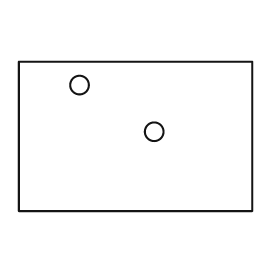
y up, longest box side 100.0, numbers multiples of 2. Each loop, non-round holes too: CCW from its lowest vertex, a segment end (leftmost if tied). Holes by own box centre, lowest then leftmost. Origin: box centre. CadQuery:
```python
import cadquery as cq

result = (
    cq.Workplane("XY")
    .moveTo(-50.0, -32.0)
    .lineTo(50.0, -32.0)
    .lineTo(50.0, 32.0)
    .lineTo(-50.0, 32.0)
    .close()
    .moveTo(8.0, 2.0)
    .circle(4.0)
    .moveTo(-24.0, 22.0)
    .circle(4.0)
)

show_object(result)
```